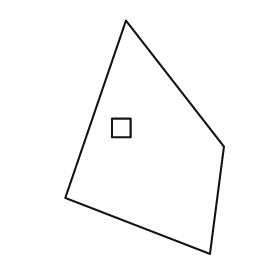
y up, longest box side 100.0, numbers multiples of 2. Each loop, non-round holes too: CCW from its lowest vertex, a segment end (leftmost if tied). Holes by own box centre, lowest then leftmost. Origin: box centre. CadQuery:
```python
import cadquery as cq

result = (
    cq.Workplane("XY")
    .moveTo(28.0, -50.0)
    .lineTo(34.0, -4.0)
    .lineTo(-8.0, 50.0)
    .lineTo(-34.0, -26.0)
    .close()
    .moveTo(-14.0, 0.0)
    .lineTo(-6.0, 0.0)
    .lineTo(-6.0, 8.0)
    .lineTo(-14.0, 8.0)
    .close()
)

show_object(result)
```